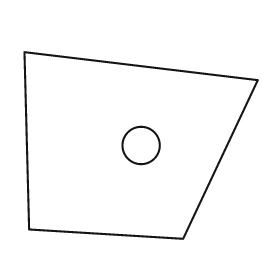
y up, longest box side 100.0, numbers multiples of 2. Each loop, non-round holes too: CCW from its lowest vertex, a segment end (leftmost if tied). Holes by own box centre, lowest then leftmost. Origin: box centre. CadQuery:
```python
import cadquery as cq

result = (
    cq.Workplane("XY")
    .moveTo(18.0, -40.0)
    .lineTo(50.0, 28.0)
    .lineTo(-50.0, 40.0)
    .lineTo(-48.0, -36.0)
    .close()
    .moveTo(0.0, 0.0)
    .circle(8.0)
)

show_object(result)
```